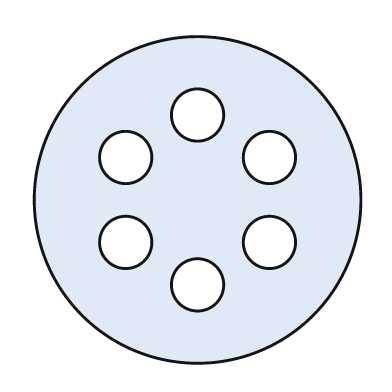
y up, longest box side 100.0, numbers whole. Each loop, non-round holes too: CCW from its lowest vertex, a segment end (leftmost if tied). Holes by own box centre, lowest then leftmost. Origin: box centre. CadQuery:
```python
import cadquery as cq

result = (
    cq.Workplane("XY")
    .moveTo(0.0, 0.0)
    .circle(50.0)
    .moveTo(0.0, -26.0)
    .circle(8.0)
    .moveTo(-22.0, -13.0)
    .circle(8.0)
    .moveTo(22.0, -13.0)
    .circle(8.0)
    .moveTo(-22.0, 13.0)
    .circle(8.0)
    .moveTo(22.0, 13.0)
    .circle(8.0)
    .moveTo(0.0, 26.0)
    .circle(8.0)
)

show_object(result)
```